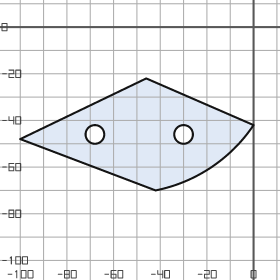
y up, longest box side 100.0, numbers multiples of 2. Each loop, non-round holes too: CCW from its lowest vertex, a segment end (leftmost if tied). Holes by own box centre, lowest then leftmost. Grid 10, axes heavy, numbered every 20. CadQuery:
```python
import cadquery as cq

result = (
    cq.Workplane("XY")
    .moveTo(-42.0, -70.0)
    .threePointArc((-18.0, -60.0), (0.0, -42.0))
    .lineTo(-46.0, -22.0)
    .lineTo(-100.0, -48.0)
    .close()
    .moveTo(-68.0, -46.0)
    .circle(4.0)
    .moveTo(-30.0, -46.0)
    .circle(4.0)
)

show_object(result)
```